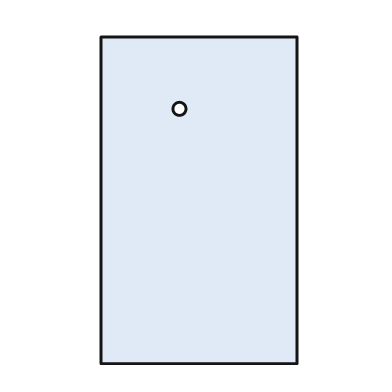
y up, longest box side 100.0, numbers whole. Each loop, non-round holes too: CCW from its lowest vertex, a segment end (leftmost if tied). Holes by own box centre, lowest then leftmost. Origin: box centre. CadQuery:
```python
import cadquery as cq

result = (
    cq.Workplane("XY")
    .moveTo(-30.0, -50.0)
    .lineTo(30.0, -50.0)
    .lineTo(30.0, 50.0)
    .lineTo(-30.0, 50.0)
    .close()
    .moveTo(-6.0, 28.0)
    .circle(2.0)
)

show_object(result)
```